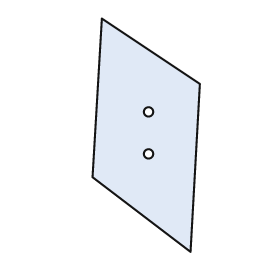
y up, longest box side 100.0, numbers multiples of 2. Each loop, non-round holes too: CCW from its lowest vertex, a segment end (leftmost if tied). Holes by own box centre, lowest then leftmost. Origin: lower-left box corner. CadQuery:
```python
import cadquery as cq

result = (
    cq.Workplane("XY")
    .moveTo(42.0, 0.0)
    .lineTo(46.0, 72.0)
    .lineTo(4.0, 100.0)
    .lineTo(0.0, 32.0)
    .close()
    .moveTo(24.0, 42.0)
    .circle(2.0)
    .moveTo(24.0, 60.0)
    .circle(2.0)
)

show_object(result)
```